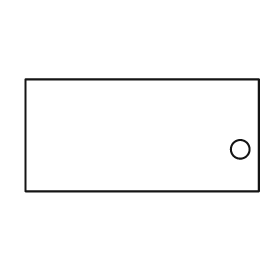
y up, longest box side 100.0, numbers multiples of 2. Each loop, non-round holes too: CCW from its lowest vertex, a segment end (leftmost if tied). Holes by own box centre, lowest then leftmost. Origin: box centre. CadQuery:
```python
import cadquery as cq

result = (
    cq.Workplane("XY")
    .moveTo(-50.0, -24.0)
    .lineTo(50.0, -24.0)
    .lineTo(50.0, 24.0)
    .lineTo(-50.0, 24.0)
    .close()
    .moveTo(42.0, -6.0)
    .circle(4.0)
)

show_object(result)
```